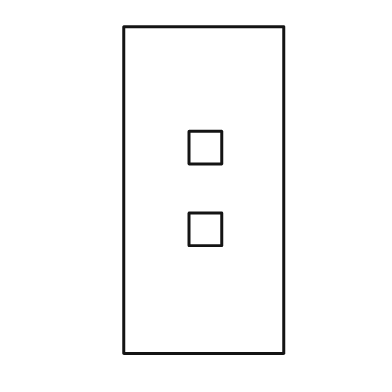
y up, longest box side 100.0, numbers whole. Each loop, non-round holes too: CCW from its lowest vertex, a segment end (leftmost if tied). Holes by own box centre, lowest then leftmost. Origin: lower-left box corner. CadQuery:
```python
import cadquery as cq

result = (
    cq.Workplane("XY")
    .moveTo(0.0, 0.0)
    .lineTo(49.0, 0.0)
    .lineTo(49.0, 100.0)
    .lineTo(0.0, 100.0)
    .close()
    .moveTo(20.0, 33.0)
    .lineTo(30.0, 33.0)
    .lineTo(30.0, 43.0)
    .lineTo(20.0, 43.0)
    .close()
    .moveTo(20.0, 58.0)
    .lineTo(30.0, 58.0)
    .lineTo(30.0, 68.0)
    .lineTo(20.0, 68.0)
    .close()
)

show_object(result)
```